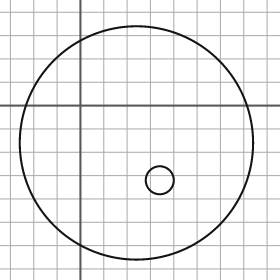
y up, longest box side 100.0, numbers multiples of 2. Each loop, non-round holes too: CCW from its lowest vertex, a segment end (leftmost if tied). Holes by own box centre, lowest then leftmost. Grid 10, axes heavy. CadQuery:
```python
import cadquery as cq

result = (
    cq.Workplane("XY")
    .moveTo(24.0, -16.0)
    .circle(50.0)
    .moveTo(34.0, -32.0)
    .circle(6.0)
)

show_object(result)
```